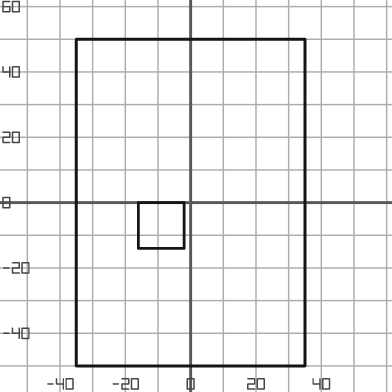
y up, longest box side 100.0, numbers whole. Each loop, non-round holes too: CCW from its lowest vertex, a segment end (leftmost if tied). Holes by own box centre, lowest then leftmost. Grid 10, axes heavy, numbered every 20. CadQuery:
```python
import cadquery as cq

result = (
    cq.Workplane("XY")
    .moveTo(-35.0, -50.0)
    .lineTo(35.0, -50.0)
    .lineTo(35.0, 50.0)
    .lineTo(-35.0, 50.0)
    .close()
    .moveTo(-16.0, -14.0)
    .lineTo(-2.0, -14.0)
    .lineTo(-2.0, 0.0)
    .lineTo(-16.0, 0.0)
    .close()
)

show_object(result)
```